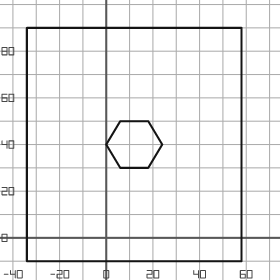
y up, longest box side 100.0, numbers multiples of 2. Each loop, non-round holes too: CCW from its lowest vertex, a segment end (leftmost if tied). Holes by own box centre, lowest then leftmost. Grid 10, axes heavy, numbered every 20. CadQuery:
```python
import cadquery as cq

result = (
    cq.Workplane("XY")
    .moveTo(-34.0, -10.0)
    .lineTo(58.0, -10.0)
    .lineTo(58.0, 90.0)
    .lineTo(-34.0, 90.0)
    .close()
    .moveTo(6.0, 30.0)
    .lineTo(18.0, 30.0)
    .lineTo(24.0, 40.0)
    .lineTo(18.0, 50.0)
    .lineTo(6.0, 50.0)
    .lineTo(0.0, 40.0)
    .close()
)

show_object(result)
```